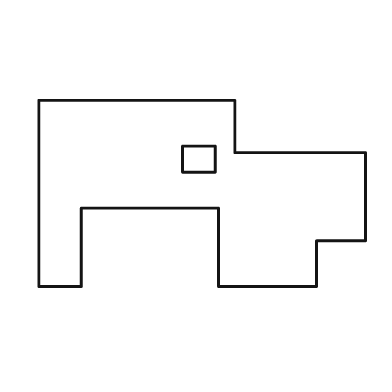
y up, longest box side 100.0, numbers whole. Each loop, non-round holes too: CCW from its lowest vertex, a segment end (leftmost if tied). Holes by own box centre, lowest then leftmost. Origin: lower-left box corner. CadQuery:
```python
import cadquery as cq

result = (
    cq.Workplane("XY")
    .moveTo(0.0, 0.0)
    .lineTo(13.0, 0.0)
    .lineTo(13.0, 24.0)
    .lineTo(55.0, 24.0)
    .lineTo(55.0, 0.0)
    .lineTo(85.0, 0.0)
    .lineTo(85.0, 14.0)
    .lineTo(100.0, 14.0)
    .lineTo(100.0, 41.0)
    .lineTo(60.0, 41.0)
    .lineTo(60.0, 57.0)
    .lineTo(0.0, 57.0)
    .close()
    .moveTo(44.0, 35.0)
    .lineTo(54.0, 35.0)
    .lineTo(54.0, 43.0)
    .lineTo(44.0, 43.0)
    .close()
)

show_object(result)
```